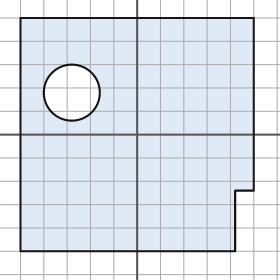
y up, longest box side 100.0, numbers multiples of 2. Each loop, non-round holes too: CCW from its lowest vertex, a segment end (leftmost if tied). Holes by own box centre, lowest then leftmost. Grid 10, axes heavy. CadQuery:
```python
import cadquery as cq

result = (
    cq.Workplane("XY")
    .moveTo(-50.0, -50.0)
    .lineTo(42.0, -50.0)
    .lineTo(42.0, -24.0)
    .lineTo(50.0, -24.0)
    .lineTo(50.0, 50.0)
    .lineTo(-50.0, 50.0)
    .close()
    .moveTo(-28.0, 18.0)
    .circle(12.0)
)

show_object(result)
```